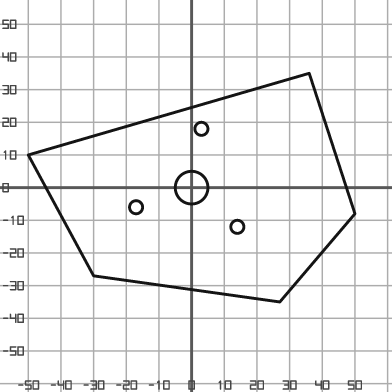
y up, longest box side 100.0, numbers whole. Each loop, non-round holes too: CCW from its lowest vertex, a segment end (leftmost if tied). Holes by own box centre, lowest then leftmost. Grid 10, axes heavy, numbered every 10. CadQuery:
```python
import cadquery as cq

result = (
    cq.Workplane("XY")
    .moveTo(27.0, -35.0)
    .lineTo(50.0, -8.0)
    .lineTo(36.0, 35.0)
    .lineTo(-50.0, 10.0)
    .lineTo(-30.0, -27.0)
    .close()
    .moveTo(14.0, -12.0)
    .circle(2.0)
    .moveTo(-17.0, -6.0)
    .circle(2.0)
    .moveTo(0.0, 0.0)
    .circle(5.0)
    .moveTo(3.0, 18.0)
    .circle(2.0)
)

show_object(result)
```